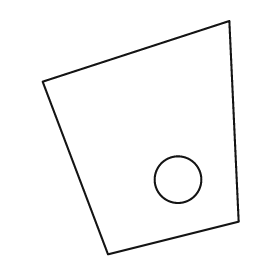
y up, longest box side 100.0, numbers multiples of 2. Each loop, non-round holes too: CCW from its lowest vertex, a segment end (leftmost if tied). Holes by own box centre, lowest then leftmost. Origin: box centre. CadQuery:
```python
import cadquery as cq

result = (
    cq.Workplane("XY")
    .moveTo(-14.0, -50.0)
    .lineTo(42.0, -36.0)
    .lineTo(38.0, 50.0)
    .lineTo(-42.0, 24.0)
    .close()
    .moveTo(16.0, -18.0)
    .circle(10.0)
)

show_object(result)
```